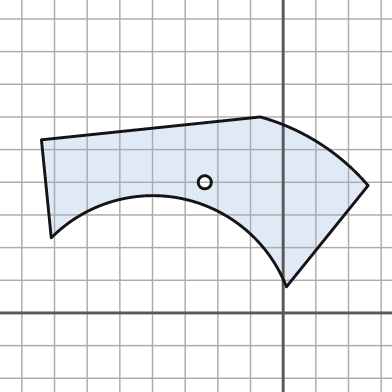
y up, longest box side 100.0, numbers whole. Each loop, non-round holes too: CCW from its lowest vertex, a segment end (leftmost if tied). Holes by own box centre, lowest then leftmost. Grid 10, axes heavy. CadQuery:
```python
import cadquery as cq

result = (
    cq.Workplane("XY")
    .moveTo(1.0, 8.0)
    .lineTo(26.0, 39.0)
    .threePointArc((11.0, 52.0), (-7.0, 60.0))
    .lineTo(-74.0, 53.0)
    .lineTo(-71.0, 23.0)
    .threePointArc((-31.0, 35.0), (1.0, 8.0))
    .close()
    .moveTo(-24.0, 40.0)
    .circle(2.0)
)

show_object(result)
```